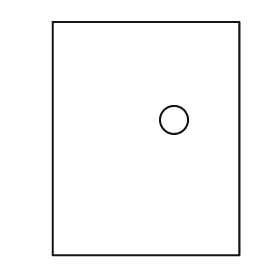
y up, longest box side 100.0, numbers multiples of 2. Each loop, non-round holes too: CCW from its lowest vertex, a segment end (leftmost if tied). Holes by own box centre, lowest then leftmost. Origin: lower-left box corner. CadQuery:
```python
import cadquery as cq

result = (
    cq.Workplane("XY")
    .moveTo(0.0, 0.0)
    .lineTo(80.0, 0.0)
    .lineTo(80.0, 100.0)
    .lineTo(0.0, 100.0)
    .close()
    .moveTo(52.0, 58.0)
    .circle(6.0)
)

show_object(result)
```